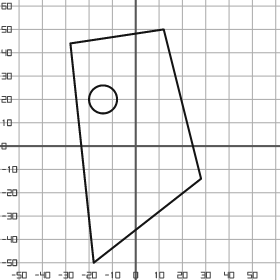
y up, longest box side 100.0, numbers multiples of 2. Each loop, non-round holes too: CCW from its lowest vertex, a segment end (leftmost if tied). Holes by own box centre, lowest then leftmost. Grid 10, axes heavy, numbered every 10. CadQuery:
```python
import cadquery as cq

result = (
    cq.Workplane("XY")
    .moveTo(-18.0, -50.0)
    .lineTo(28.0, -14.0)
    .lineTo(12.0, 50.0)
    .lineTo(-28.0, 44.0)
    .close()
    .moveTo(-14.0, 20.0)
    .circle(6.0)
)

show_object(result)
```